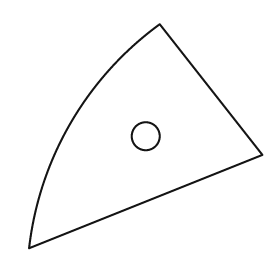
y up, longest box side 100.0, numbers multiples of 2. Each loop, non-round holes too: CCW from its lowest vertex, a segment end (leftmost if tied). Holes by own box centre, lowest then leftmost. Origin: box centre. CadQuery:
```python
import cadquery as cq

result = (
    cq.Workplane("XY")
    .moveTo(-50.0, -48.0)
    .lineTo(50.0, -8.0)
    .lineTo(6.0, 48.0)
    .threePointArc((-32.0, 6.0), (-50.0, -48.0))
    .close()
    .moveTo(0.0, 0.0)
    .circle(6.0)
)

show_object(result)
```